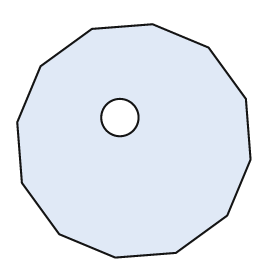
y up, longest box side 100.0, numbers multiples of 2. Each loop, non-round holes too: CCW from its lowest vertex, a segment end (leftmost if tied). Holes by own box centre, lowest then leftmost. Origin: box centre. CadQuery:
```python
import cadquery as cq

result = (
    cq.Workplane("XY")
    .moveTo(-8.0, -50.0)
    .lineTo(18.0, -48.0)
    .lineTo(40.0, -32.0)
    .lineTo(50.0, -8.0)
    .lineTo(48.0, 18.0)
    .lineTo(32.0, 40.0)
    .lineTo(8.0, 50.0)
    .lineTo(-18.0, 48.0)
    .lineTo(-40.0, 32.0)
    .lineTo(-50.0, 8.0)
    .lineTo(-48.0, -18.0)
    .lineTo(-32.0, -40.0)
    .close()
    .moveTo(-6.0, 10.0)
    .circle(8.0)
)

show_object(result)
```